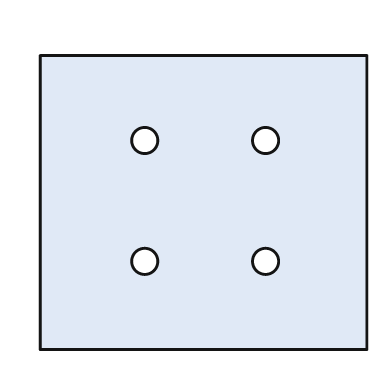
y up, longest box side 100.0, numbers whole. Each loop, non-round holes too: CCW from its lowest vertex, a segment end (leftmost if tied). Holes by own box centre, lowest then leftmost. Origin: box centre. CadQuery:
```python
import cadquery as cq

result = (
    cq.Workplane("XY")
    .moveTo(-50.0, -45.0)
    .lineTo(50.0, -45.0)
    .lineTo(50.0, 45.0)
    .lineTo(-50.0, 45.0)
    .close()
    .moveTo(-18.0, -18.0)
    .circle(4.0)
    .moveTo(19.0, -18.0)
    .circle(4.0)
    .moveTo(-18.0, 19.0)
    .circle(4.0)
    .moveTo(19.0, 19.0)
    .circle(4.0)
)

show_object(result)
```